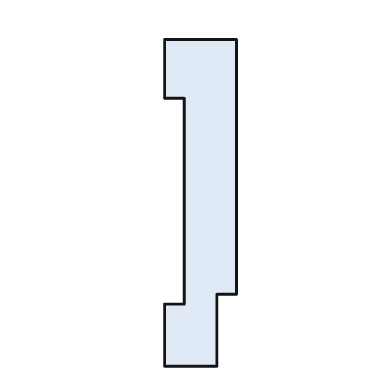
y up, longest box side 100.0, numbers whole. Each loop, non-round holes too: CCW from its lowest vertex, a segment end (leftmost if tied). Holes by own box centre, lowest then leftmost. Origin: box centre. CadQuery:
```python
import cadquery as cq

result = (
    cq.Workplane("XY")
    .moveTo(-11.0, -50.0)
    .lineTo(5.0, -50.0)
    .lineTo(5.0, -28.0)
    .lineTo(11.0, -28.0)
    .lineTo(11.0, 50.0)
    .lineTo(-11.0, 50.0)
    .lineTo(-11.0, 32.0)
    .lineTo(-5.0, 32.0)
    .lineTo(-5.0, -31.0)
    .lineTo(-11.0, -31.0)
    .close()
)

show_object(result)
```